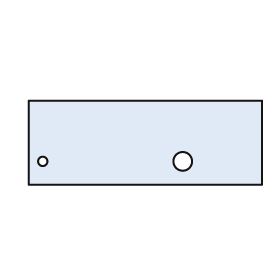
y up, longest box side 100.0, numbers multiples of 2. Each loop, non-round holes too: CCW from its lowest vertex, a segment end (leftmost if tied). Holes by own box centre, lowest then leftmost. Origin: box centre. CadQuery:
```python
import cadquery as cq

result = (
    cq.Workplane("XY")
    .moveTo(-50.0, -18.0)
    .lineTo(50.0, -18.0)
    .lineTo(50.0, 18.0)
    .lineTo(-50.0, 18.0)
    .close()
    .moveTo(-44.0, -8.0)
    .circle(2.0)
    .moveTo(16.0, -8.0)
    .circle(4.0)
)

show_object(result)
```